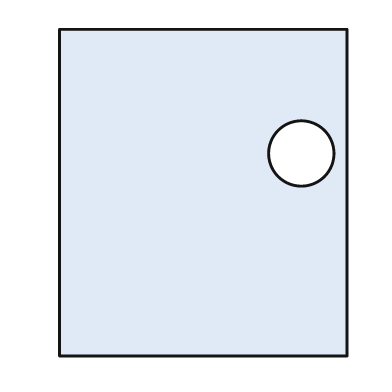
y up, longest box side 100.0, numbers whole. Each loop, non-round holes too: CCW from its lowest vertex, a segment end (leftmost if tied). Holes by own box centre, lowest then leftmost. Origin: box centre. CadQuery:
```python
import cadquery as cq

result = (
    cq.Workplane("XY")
    .moveTo(-44.0, -50.0)
    .lineTo(44.0, -50.0)
    .lineTo(44.0, 50.0)
    .lineTo(-44.0, 50.0)
    .close()
    .moveTo(30.0, 12.0)
    .circle(10.0)
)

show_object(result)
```